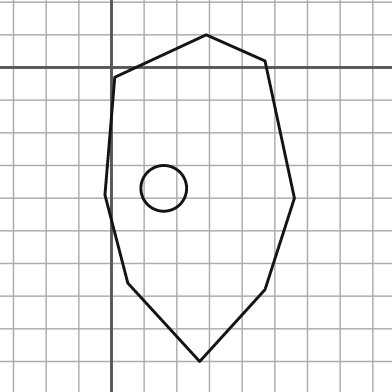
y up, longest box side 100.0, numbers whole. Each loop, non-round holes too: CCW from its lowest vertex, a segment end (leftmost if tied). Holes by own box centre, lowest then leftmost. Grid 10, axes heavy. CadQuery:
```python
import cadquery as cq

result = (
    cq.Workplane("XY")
    .moveTo(27.0, -90.0)
    .lineTo(47.0, -68.0)
    .lineTo(56.0, -40.0)
    .lineTo(47.0, 2.0)
    .lineTo(29.0, 10.0)
    .lineTo(1.0, -3.0)
    .lineTo(-2.0, -39.0)
    .lineTo(5.0, -66.0)
    .close()
    .moveTo(16.0, -37.0)
    .circle(7.0)
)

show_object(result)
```